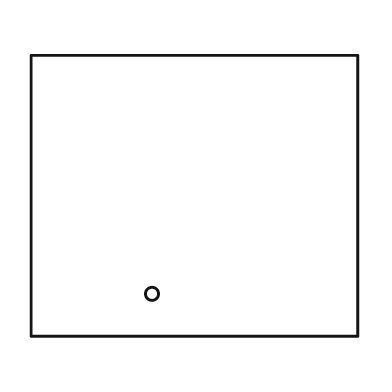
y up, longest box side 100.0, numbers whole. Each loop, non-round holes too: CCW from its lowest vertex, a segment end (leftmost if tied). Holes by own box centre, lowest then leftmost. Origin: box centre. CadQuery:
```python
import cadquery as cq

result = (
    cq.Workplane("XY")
    .moveTo(-50.0, -43.0)
    .lineTo(50.0, -43.0)
    .lineTo(50.0, 43.0)
    .lineTo(-50.0, 43.0)
    .close()
    .moveTo(-13.0, -30.0)
    .circle(2.0)
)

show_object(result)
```